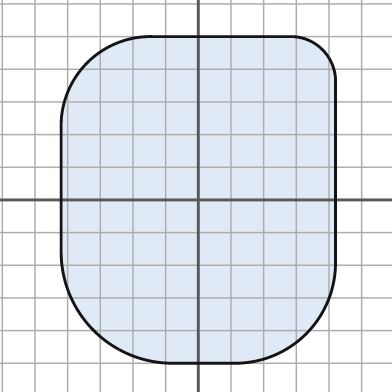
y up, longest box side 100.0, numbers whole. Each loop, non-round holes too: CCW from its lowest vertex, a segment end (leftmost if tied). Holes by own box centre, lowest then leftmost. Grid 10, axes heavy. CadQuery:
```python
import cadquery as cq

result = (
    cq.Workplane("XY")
    .moveTo(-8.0, -50.0)
    .lineTo(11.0, -50.0)
    .threePointArc((33.0, -41.0), (42.0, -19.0))
    .lineTo(42.0, 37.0)
    .threePointArc((38.0, 46.0), (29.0, 50.0))
    .lineTo(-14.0, 50.0)
    .threePointArc((-34.0, 42.0), (-42.0, 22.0))
    .lineTo(-42.0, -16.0)
    .threePointArc((-32.0, -40.0), (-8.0, -50.0))
    .close()
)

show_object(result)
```